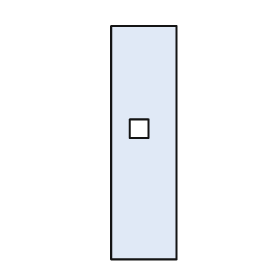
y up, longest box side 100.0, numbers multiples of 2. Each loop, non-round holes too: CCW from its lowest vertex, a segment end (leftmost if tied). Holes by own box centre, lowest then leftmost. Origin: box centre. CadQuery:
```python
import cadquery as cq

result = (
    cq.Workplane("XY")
    .moveTo(-14.0, -50.0)
    .lineTo(14.0, -50.0)
    .lineTo(14.0, 50.0)
    .lineTo(-14.0, 50.0)
    .close()
    .moveTo(-6.0, 2.0)
    .lineTo(2.0, 2.0)
    .lineTo(2.0, 10.0)
    .lineTo(-6.0, 10.0)
    .close()
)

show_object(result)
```